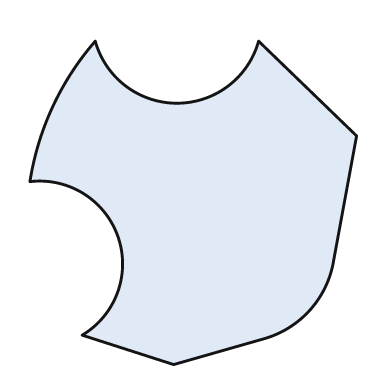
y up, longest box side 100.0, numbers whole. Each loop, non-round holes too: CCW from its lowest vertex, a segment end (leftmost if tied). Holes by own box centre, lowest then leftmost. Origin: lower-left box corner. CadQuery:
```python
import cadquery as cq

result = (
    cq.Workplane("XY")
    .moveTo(44.0, 0.0)
    .lineTo(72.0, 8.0)
    .threePointArc((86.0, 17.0), (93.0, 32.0))
    .lineTo(100.0, 70.0)
    .lineTo(70.0, 99.0)
    .threePointArc((45.0, 80.0), (20.0, 99.0))
    .threePointArc((7.0, 79.0), (0.0, 56.0))
    .threePointArc((27.0, 39.0), (16.0, 9.0))
    .close()
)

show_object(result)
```